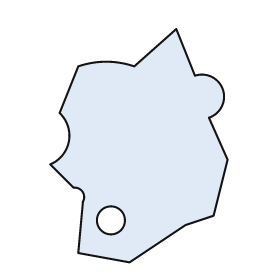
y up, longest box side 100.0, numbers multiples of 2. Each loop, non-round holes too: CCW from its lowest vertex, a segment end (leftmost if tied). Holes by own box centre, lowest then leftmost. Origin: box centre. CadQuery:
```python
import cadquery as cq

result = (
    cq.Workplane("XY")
    .moveTo(-4.0, -50.0)
    .lineTo(20.0, -34.0)
    .lineTo(32.0, -30.0)
    .lineTo(38.0, -6.0)
    .lineTo(30.0, 12.0)
    .threePointArc((36.0, 24.0), (24.0, 30.0))
    .lineTo(16.0, 50.0)
    .lineTo(-2.0, 34.0)
    .threePointArc((-14.0, 36.0), (-26.0, 34.0))
    .lineTo(-34.0, 14.0)
    .threePointArc((-30.0, 2.0), (-38.0, -8.0))
    .lineTo(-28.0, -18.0)
    .threePointArc((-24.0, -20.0), (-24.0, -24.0))
    .lineTo(-26.0, -46.0)
    .close()
    .moveTo(-12.0, -32.0)
    .circle(6.0)
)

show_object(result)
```